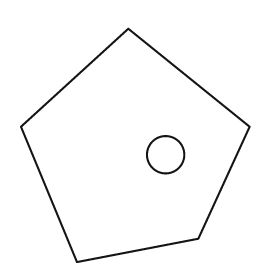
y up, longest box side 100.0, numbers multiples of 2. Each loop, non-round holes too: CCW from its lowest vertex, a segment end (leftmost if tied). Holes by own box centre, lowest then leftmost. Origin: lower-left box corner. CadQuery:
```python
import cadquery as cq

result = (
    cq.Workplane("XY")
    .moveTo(24.0, 0.0)
    .lineTo(76.0, 10.0)
    .lineTo(98.0, 58.0)
    .lineTo(46.0, 100.0)
    .lineTo(0.0, 58.0)
    .close()
    .moveTo(62.0, 46.0)
    .circle(8.0)
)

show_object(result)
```